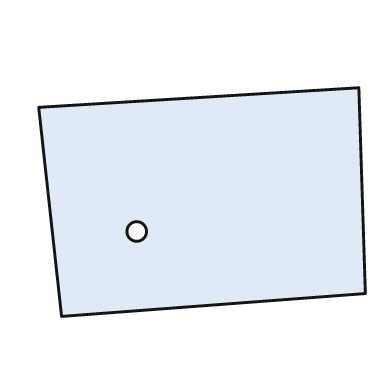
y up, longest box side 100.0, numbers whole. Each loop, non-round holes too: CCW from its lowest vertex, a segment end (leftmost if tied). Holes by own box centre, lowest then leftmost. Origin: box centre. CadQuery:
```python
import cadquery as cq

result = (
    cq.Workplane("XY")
    .moveTo(-43.0, -35.0)
    .lineTo(50.0, -28.0)
    .lineTo(48.0, 35.0)
    .lineTo(-50.0, 29.0)
    .close()
    .moveTo(-20.0, -9.0)
    .circle(3.0)
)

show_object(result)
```